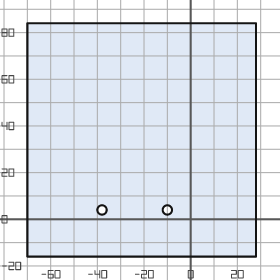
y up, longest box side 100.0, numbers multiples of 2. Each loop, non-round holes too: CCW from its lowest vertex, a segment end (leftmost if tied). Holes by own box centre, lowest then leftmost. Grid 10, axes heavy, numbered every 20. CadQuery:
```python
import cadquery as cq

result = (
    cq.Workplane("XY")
    .moveTo(-70.0, -16.0)
    .lineTo(28.0, -16.0)
    .lineTo(28.0, 84.0)
    .lineTo(-70.0, 84.0)
    .close()
    .moveTo(-38.0, 4.0)
    .circle(2.0)
    .moveTo(-10.0, 4.0)
    .circle(2.0)
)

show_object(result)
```